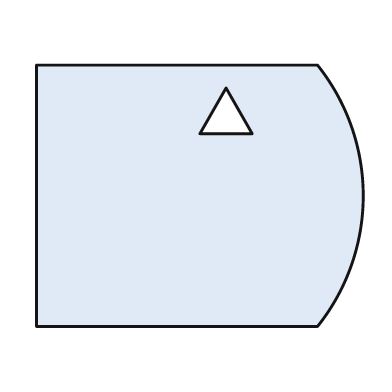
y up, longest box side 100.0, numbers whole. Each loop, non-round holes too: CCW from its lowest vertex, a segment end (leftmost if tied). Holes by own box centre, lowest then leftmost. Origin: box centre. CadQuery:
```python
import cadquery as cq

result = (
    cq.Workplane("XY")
    .moveTo(-50.0, -40.0)
    .lineTo(36.0, -40.0)
    .threePointArc((50.0, 0.0), (36.0, 40.0))
    .lineTo(-50.0, 40.0)
    .close()
    .moveTo(0.0, 19.0)
    .lineTo(16.0, 19.0)
    .lineTo(8.0, 33.0)
    .close()
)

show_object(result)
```